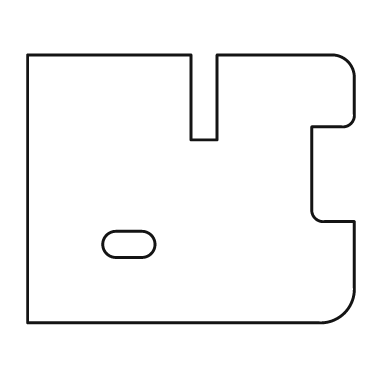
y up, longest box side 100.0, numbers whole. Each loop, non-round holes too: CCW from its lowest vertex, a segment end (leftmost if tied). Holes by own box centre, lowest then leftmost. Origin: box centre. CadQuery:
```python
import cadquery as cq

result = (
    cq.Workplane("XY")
    .moveTo(-50.0, -41.0)
    .lineTo(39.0, -41.0)
    .threePointArc((47.0, -38.0), (50.0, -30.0))
    .lineTo(50.0, -10.0)
    .lineTo(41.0, -10.0)
    .threePointArc((38.0, -9.0), (37.0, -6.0))
    .lineTo(37.0, 19.0)
    .lineTo(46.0, 19.0)
    .threePointArc((49.0, 20.0), (50.0, 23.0))
    .lineTo(50.0, 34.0)
    .threePointArc((48.0, 39.0), (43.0, 41.0))
    .lineTo(8.0, 41.0)
    .lineTo(8.0, 15.0)
    .lineTo(0.0, 15.0)
    .lineTo(0.0, 41.0)
    .lineTo(-50.0, 41.0)
    .close()
    .moveTo(-23.0, -21.0)
    .lineTo(-15.0, -21.0)
    .threePointArc((-11.0, -17.0), (-15.0, -13.0))
    .lineTo(-23.0, -13.0)
    .threePointArc((-27.0, -17.0), (-23.0, -21.0))
    .close()
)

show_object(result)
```